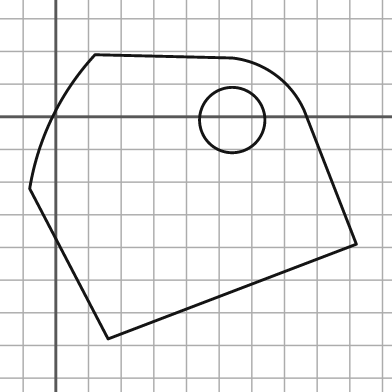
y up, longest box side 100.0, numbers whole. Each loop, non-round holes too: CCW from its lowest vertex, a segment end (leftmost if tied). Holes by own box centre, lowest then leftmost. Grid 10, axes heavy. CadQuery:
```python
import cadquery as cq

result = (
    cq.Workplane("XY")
    .moveTo(16.0, -68.0)
    .lineTo(92.0, -39.0)
    .lineTo(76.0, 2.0)
    .threePointArc((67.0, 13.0), (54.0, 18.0))
    .lineTo(12.0, 19.0)
    .threePointArc((-1.0, 0.0), (-8.0, -22.0))
    .close()
    .moveTo(54.0, -1.0)
    .circle(10.0)
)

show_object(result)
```